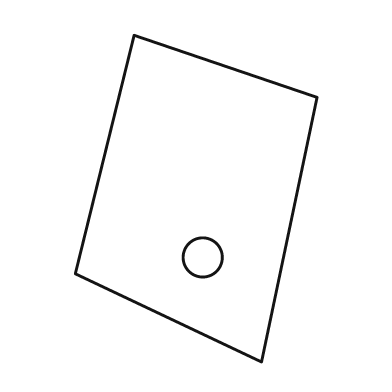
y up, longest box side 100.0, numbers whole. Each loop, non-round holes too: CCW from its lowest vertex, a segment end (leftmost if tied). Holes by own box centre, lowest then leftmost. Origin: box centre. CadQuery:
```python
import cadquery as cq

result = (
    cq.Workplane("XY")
    .moveTo(20.0, -50.0)
    .lineTo(37.0, 31.0)
    .lineTo(-19.0, 50.0)
    .lineTo(-37.0, -23.0)
    .close()
    .moveTo(2.0, -18.0)
    .circle(6.0)
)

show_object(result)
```